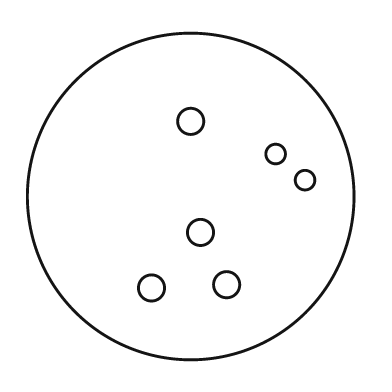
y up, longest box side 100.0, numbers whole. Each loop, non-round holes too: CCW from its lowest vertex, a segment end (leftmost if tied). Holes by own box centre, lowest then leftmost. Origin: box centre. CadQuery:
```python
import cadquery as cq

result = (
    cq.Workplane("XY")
    .moveTo(0.0, 0.0)
    .circle(50.0)
    .moveTo(-12.0, -28.0)
    .circle(4.0)
    .moveTo(11.0, -27.0)
    .circle(4.0)
    .moveTo(3.0, -11.0)
    .circle(4.0)
    .moveTo(35.0, 5.0)
    .circle(3.0)
    .moveTo(26.0, 13.0)
    .circle(3.0)
    .moveTo(0.0, 23.0)
    .circle(4.0)
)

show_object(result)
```